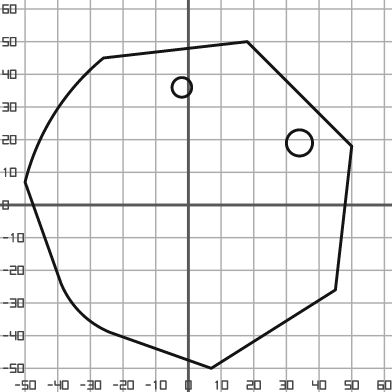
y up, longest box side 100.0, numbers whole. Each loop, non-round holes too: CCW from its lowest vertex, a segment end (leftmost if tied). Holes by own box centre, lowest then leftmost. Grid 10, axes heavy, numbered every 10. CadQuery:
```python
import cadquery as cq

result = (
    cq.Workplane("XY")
    .moveTo(7.0, -50.0)
    .lineTo(45.0, -26.0)
    .lineTo(50.0, 18.0)
    .lineTo(18.0, 50.0)
    .lineTo(-26.0, 45.0)
    .threePointArc((-41.0, 28.0), (-50.0, 7.0))
    .lineTo(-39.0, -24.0)
    .threePointArc((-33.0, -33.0), (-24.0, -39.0))
    .close()
    .moveTo(34.0, 19.0)
    .circle(4.0)
    .moveTo(-2.0, 36.0)
    .circle(3.0)
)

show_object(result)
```